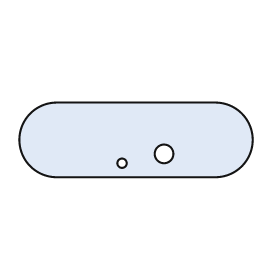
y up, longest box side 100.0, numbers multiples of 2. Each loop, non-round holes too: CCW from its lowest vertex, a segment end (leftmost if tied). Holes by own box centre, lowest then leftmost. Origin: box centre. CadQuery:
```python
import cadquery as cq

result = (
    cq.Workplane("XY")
    .moveTo(-34.0, -16.0)
    .lineTo(34.0, -16.0)
    .threePointArc((50.0, 0.0), (34.0, 16.0))
    .lineTo(-34.0, 16.0)
    .threePointArc((-50.0, 0.0), (-34.0, -16.0))
    .close()
    .moveTo(-6.0, -10.0)
    .circle(2.0)
    .moveTo(12.0, -6.0)
    .circle(4.0)
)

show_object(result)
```